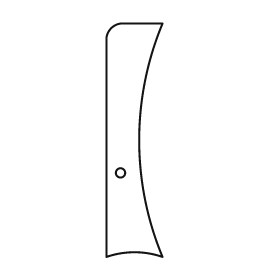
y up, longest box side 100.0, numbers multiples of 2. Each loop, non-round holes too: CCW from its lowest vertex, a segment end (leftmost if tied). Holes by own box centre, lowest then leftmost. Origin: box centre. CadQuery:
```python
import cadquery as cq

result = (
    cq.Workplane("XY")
    .moveTo(-12.0, -50.0)
    .threePointArc((0.0, -48.0), (12.0, -50.0))
    .threePointArc((2.0, 0.0), (12.0, 50.0))
    .lineTo(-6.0, 50.0)
    .threePointArc((-10.0, 48.0), (-12.0, 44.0))
    .close()
    .moveTo(-6.0, -14.0)
    .circle(2.0)
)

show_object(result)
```